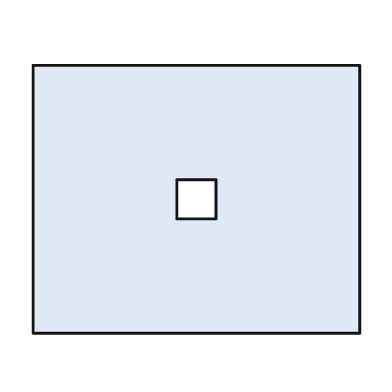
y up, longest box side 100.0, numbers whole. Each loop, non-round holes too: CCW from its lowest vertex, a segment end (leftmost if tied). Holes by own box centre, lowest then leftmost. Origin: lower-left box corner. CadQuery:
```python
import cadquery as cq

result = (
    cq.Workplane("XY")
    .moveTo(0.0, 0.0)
    .lineTo(100.0, 0.0)
    .lineTo(100.0, 82.0)
    .lineTo(0.0, 82.0)
    .close()
    .moveTo(44.0, 35.0)
    .lineTo(56.0, 35.0)
    .lineTo(56.0, 47.0)
    .lineTo(44.0, 47.0)
    .close()
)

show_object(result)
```